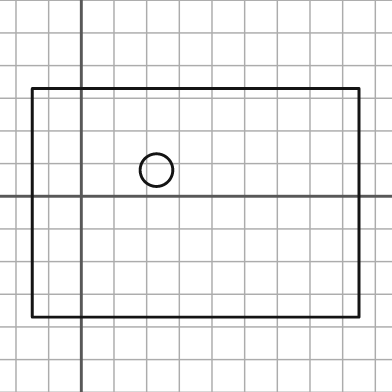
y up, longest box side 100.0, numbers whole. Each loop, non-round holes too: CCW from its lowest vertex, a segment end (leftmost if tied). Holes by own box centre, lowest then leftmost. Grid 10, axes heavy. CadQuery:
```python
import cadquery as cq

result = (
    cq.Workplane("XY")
    .moveTo(-15.0, -37.0)
    .lineTo(85.0, -37.0)
    .lineTo(85.0, 33.0)
    .lineTo(-15.0, 33.0)
    .close()
    .moveTo(23.0, 8.0)
    .circle(5.0)
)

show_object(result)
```